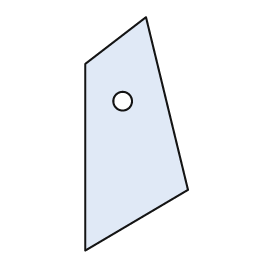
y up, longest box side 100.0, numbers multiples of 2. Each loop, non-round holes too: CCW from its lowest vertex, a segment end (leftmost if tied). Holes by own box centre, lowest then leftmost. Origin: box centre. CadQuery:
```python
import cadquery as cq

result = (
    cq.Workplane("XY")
    .moveTo(-22.0, -50.0)
    .lineTo(22.0, -24.0)
    .lineTo(4.0, 50.0)
    .lineTo(-22.0, 30.0)
    .close()
    .moveTo(-6.0, 14.0)
    .circle(4.0)
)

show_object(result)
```